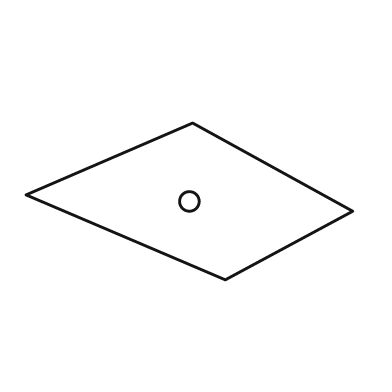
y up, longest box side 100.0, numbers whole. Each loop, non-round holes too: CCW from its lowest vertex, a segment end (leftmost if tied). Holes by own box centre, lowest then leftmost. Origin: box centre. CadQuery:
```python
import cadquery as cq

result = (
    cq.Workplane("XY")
    .moveTo(11.0, -24.0)
    .lineTo(50.0, -3.0)
    .lineTo(1.0, 24.0)
    .lineTo(-50.0, 2.0)
    .close()
    .moveTo(0.0, 0.0)
    .circle(3.0)
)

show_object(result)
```